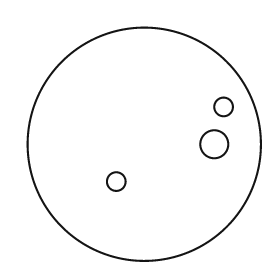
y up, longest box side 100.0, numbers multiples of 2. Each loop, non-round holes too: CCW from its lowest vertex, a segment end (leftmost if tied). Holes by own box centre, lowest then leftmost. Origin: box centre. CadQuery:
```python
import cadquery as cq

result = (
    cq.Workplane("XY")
    .moveTo(0.0, 0.0)
    .circle(50.0)
    .moveTo(-12.0, -16.0)
    .circle(4.0)
    .moveTo(30.0, 0.0)
    .circle(6.0)
    .moveTo(34.0, 16.0)
    .circle(4.0)
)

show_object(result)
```